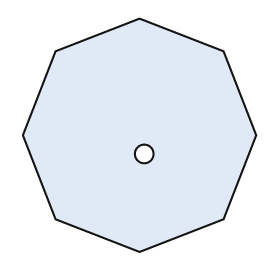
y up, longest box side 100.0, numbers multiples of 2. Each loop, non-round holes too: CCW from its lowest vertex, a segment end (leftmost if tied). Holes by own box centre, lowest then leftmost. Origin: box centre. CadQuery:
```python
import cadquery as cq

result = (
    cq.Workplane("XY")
    .moveTo(0.0, -50.0)
    .lineTo(36.0, -36.0)
    .lineTo(50.0, 0.0)
    .lineTo(36.0, 36.0)
    .lineTo(0.0, 50.0)
    .lineTo(-36.0, 36.0)
    .lineTo(-50.0, 0.0)
    .lineTo(-36.0, -36.0)
    .close()
    .moveTo(2.0, -8.0)
    .circle(4.0)
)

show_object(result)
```